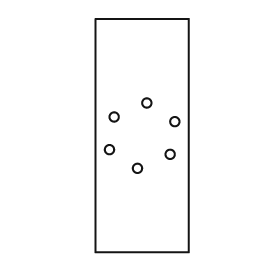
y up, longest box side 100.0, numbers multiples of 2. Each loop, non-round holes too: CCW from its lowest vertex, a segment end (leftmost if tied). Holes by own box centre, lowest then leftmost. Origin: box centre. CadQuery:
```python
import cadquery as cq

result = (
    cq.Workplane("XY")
    .moveTo(-20.0, -50.0)
    .lineTo(20.0, -50.0)
    .lineTo(20.0, 50.0)
    .lineTo(-20.0, 50.0)
    .close()
    .moveTo(-2.0, -14.0)
    .circle(2.0)
    .moveTo(12.0, -8.0)
    .circle(2.0)
    .moveTo(-14.0, -6.0)
    .circle(2.0)
    .moveTo(14.0, 6.0)
    .circle(2.0)
    .moveTo(-12.0, 8.0)
    .circle(2.0)
    .moveTo(2.0, 14.0)
    .circle(2.0)
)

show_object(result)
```